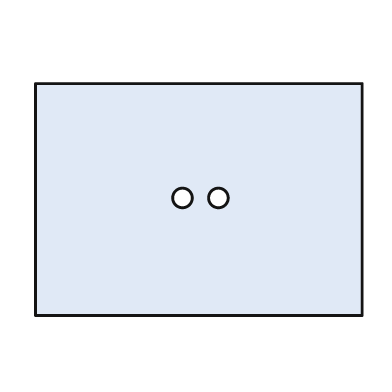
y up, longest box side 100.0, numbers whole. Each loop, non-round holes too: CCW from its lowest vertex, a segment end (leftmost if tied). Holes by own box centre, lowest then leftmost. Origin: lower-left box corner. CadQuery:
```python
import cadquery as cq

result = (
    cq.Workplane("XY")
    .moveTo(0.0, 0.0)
    .lineTo(100.0, 0.0)
    .lineTo(100.0, 71.0)
    .lineTo(0.0, 71.0)
    .close()
    .moveTo(45.0, 36.0)
    .circle(3.0)
    .moveTo(56.0, 36.0)
    .circle(3.0)
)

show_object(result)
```